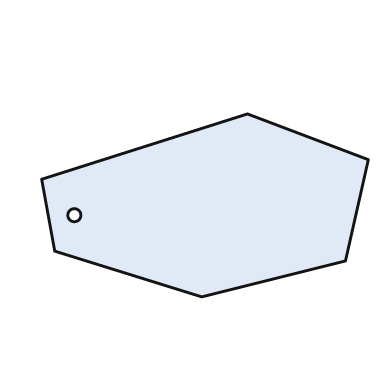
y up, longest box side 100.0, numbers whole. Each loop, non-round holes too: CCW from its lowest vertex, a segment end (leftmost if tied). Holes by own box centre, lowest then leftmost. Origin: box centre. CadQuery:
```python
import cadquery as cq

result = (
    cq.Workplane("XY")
    .moveTo(-1.0, -28.0)
    .lineTo(43.0, -17.0)
    .lineTo(50.0, 14.0)
    .lineTo(13.0, 28.0)
    .lineTo(-50.0, 8.0)
    .lineTo(-46.0, -14.0)
    .close()
    .moveTo(-40.0, -3.0)
    .circle(2.0)
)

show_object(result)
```